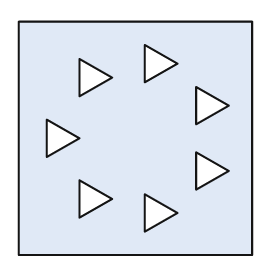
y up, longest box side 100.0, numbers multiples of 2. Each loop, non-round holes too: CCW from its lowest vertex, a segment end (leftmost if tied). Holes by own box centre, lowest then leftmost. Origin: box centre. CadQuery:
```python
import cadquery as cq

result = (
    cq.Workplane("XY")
    .moveTo(-50.0, -50.0)
    .lineTo(50.0, -50.0)
    .lineTo(50.0, 50.0)
    .lineTo(-50.0, 50.0)
    .close()
    .moveTo(4.0, -40.0)
    .lineTo(18.0, -32.0)
    .lineTo(4.0, -24.0)
    .close()
    .moveTo(-24.0, -34.0)
    .lineTo(-10.0, -26.0)
    .lineTo(-24.0, -18.0)
    .close()
    .moveTo(26.0, -22.0)
    .lineTo(40.0, -14.0)
    .lineTo(26.0, -6.0)
    .close()
    .moveTo(-38.0, -8.0)
    .lineTo(-24.0, 0.0)
    .lineTo(-38.0, 8.0)
    .close()
    .moveTo(26.0, 6.0)
    .lineTo(40.0, 14.0)
    .lineTo(26.0, 22.0)
    .close()
    .moveTo(-24.0, 18.0)
    .lineTo(-10.0, 26.0)
    .lineTo(-24.0, 34.0)
    .close()
    .moveTo(4.0, 24.0)
    .lineTo(18.0, 32.0)
    .lineTo(4.0, 40.0)
    .close()
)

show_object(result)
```